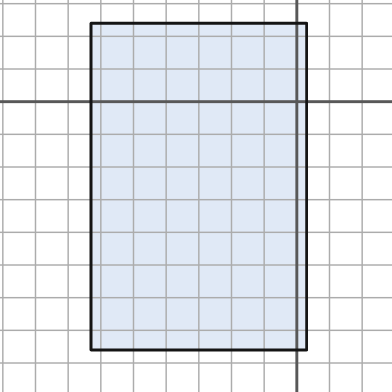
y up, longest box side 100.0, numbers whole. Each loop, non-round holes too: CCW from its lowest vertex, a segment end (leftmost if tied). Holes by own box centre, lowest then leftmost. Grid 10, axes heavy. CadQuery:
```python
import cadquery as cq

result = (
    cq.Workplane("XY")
    .moveTo(-63.0, -76.0)
    .lineTo(3.0, -76.0)
    .lineTo(3.0, 24.0)
    .lineTo(-63.0, 24.0)
    .close()
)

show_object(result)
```